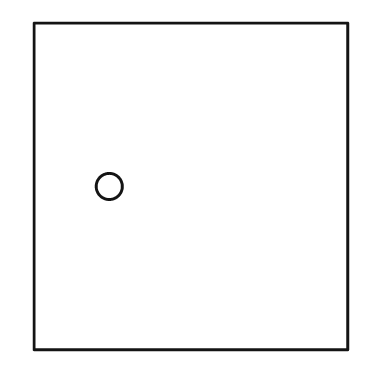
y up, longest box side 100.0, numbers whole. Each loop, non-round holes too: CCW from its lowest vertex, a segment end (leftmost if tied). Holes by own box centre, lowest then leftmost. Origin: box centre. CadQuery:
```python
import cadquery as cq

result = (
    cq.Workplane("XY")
    .moveTo(-48.0, -50.0)
    .lineTo(48.0, -50.0)
    .lineTo(48.0, 50.0)
    .lineTo(-48.0, 50.0)
    .close()
    .moveTo(-25.0, 0.0)
    .circle(4.0)
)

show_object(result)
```